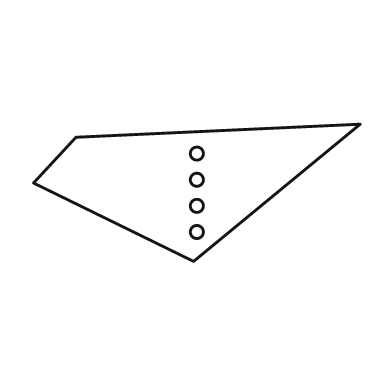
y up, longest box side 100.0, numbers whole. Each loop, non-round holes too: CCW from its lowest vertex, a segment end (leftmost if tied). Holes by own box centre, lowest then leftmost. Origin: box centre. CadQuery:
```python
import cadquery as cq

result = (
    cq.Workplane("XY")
    .moveTo(-1.0, -21.0)
    .lineTo(50.0, 21.0)
    .lineTo(-37.0, 17.0)
    .lineTo(-50.0, 3.0)
    .close()
    .moveTo(0.0, -12.0)
    .circle(2.0)
    .moveTo(0.0, -4.0)
    .circle(2.0)
    .moveTo(0.0, 4.0)
    .circle(2.0)
    .moveTo(0.0, 12.0)
    .circle(2.0)
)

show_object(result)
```